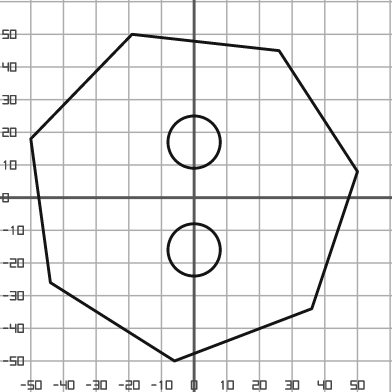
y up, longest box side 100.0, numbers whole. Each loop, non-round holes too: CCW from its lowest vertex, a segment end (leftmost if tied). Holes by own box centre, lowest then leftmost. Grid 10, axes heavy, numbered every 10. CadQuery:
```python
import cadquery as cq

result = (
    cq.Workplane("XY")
    .moveTo(-6.0, -50.0)
    .lineTo(36.0, -34.0)
    .lineTo(50.0, 8.0)
    .lineTo(26.0, 45.0)
    .lineTo(-19.0, 50.0)
    .lineTo(-50.0, 18.0)
    .lineTo(-44.0, -26.0)
    .close()
    .moveTo(0.0, -16.0)
    .circle(8.0)
    .moveTo(0.0, 17.0)
    .circle(8.0)
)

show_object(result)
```